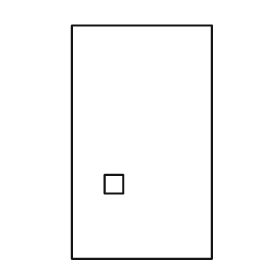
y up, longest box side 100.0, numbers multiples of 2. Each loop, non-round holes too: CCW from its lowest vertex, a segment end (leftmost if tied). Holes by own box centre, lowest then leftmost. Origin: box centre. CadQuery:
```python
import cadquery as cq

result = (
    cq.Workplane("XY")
    .moveTo(-30.0, -50.0)
    .lineTo(30.0, -50.0)
    .lineTo(30.0, 50.0)
    .lineTo(-30.0, 50.0)
    .close()
    .moveTo(-16.0, -22.0)
    .lineTo(-8.0, -22.0)
    .lineTo(-8.0, -14.0)
    .lineTo(-16.0, -14.0)
    .close()
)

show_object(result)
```